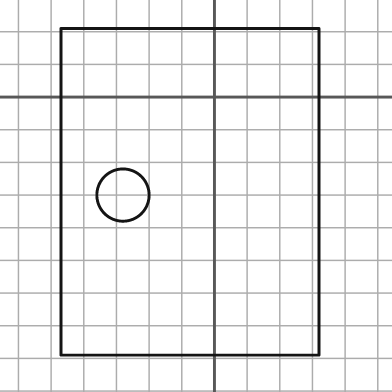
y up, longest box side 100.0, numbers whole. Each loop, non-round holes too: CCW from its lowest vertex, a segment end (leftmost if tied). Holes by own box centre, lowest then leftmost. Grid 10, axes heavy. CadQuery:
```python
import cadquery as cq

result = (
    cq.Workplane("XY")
    .moveTo(-47.0, -79.0)
    .lineTo(32.0, -79.0)
    .lineTo(32.0, 21.0)
    .lineTo(-47.0, 21.0)
    .close()
    .moveTo(-28.0, -30.0)
    .circle(8.0)
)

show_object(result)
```